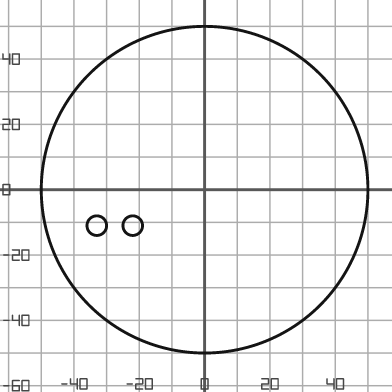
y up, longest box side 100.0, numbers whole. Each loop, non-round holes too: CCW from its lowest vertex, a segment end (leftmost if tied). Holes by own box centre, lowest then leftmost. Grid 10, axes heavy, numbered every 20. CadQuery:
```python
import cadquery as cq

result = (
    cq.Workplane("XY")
    .moveTo(0.0, 0.0)
    .circle(50.0)
    .moveTo(-33.0, -11.0)
    .circle(3.0)
    .moveTo(-22.0, -11.0)
    .circle(3.0)
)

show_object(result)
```